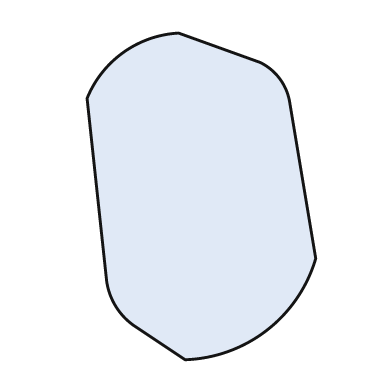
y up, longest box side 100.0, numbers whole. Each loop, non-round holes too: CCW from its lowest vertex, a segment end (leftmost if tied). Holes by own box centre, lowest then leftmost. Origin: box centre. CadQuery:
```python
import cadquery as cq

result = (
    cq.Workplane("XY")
    .moveTo(-5.0, -50.0)
    .threePointArc((20.0, -41.0), (35.0, -19.0))
    .lineTo(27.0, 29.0)
    .threePointArc((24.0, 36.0), (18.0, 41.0))
    .lineTo(-7.0, 50.0)
    .threePointArc((-24.0, 44.0), (-35.0, 30.0))
    .lineTo(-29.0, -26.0)
    .threePointArc((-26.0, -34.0), (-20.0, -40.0))
    .close()
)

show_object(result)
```